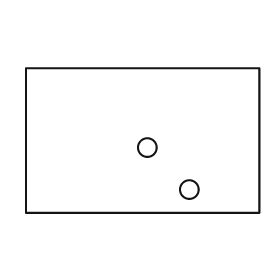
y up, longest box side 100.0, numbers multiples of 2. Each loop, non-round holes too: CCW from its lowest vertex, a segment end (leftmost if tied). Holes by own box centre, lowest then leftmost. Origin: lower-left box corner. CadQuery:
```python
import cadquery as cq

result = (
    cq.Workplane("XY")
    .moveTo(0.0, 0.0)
    .lineTo(100.0, 0.0)
    .lineTo(100.0, 62.0)
    .lineTo(0.0, 62.0)
    .close()
    .moveTo(70.0, 10.0)
    .circle(4.0)
    .moveTo(52.0, 28.0)
    .circle(4.0)
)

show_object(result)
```